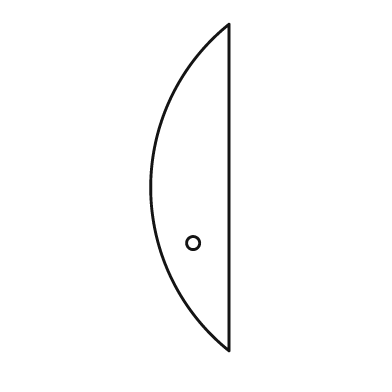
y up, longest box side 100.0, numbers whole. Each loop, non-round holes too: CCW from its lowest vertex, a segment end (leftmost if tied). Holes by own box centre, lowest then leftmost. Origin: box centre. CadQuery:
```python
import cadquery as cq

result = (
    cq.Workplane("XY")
    .moveTo(12.0, -50.0)
    .lineTo(12.0, 50.0)
    .threePointArc((-12.0, 0.0), (12.0, -50.0))
    .close()
    .moveTo(1.0, -17.0)
    .circle(2.0)
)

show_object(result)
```